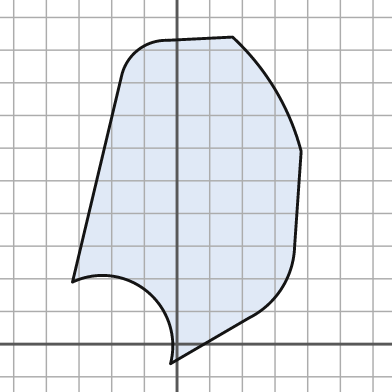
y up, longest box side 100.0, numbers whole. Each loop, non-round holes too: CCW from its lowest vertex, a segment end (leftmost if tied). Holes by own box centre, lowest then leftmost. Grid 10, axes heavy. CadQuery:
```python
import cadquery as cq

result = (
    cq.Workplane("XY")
    .moveTo(-2.0, -6.0)
    .lineTo(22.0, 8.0)
    .threePointArc((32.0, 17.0), (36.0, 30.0))
    .lineTo(38.0, 59.0)
    .threePointArc((30.0, 78.0), (17.0, 94.0))
    .lineTo(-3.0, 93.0)
    .threePointArc((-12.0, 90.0), (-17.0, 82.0))
    .lineTo(-32.0, 19.0)
    .threePointArc((-9.0, 16.0), (-2.0, -6.0))
    .close()
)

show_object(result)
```